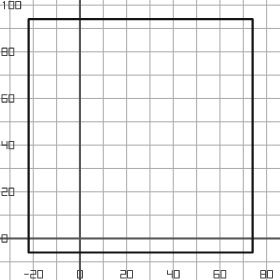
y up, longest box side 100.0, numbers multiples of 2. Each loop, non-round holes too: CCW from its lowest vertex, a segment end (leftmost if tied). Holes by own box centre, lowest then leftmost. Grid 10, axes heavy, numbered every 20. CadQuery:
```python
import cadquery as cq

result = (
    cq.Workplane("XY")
    .moveTo(-22.0, -6.0)
    .lineTo(74.0, -6.0)
    .lineTo(74.0, 94.0)
    .lineTo(-22.0, 94.0)
    .close()
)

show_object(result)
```